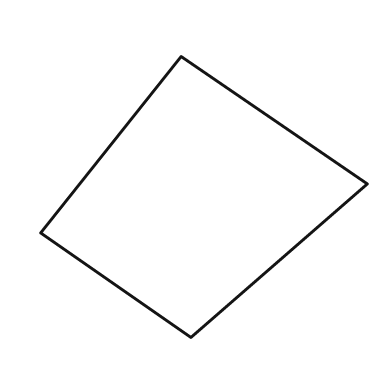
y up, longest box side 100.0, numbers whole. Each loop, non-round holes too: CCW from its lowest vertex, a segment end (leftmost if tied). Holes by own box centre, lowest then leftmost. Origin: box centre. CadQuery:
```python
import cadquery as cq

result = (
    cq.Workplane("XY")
    .moveTo(-4.0, -43.0)
    .lineTo(50.0, 4.0)
    .lineTo(-7.0, 43.0)
    .lineTo(-50.0, -11.0)
    .close()
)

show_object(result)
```